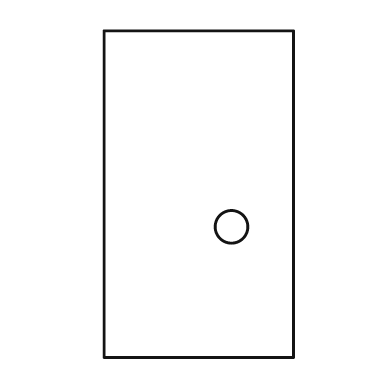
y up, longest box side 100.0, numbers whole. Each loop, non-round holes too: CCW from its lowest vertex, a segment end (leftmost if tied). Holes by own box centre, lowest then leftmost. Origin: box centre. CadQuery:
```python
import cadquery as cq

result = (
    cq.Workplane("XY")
    .moveTo(-29.0, -50.0)
    .lineTo(29.0, -50.0)
    .lineTo(29.0, 50.0)
    .lineTo(-29.0, 50.0)
    .close()
    .moveTo(10.0, -10.0)
    .circle(5.0)
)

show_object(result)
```